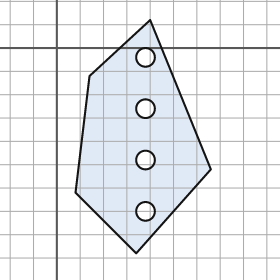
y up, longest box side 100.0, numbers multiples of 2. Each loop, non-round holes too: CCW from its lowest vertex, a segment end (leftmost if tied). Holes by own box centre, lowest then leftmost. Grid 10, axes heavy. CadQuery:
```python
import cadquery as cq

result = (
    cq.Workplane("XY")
    .moveTo(34.0, -88.0)
    .lineTo(66.0, -52.0)
    .lineTo(40.0, 12.0)
    .lineTo(14.0, -12.0)
    .lineTo(8.0, -62.0)
    .close()
    .moveTo(38.0, -70.0)
    .circle(4.0)
    .moveTo(38.0, -48.0)
    .circle(4.0)
    .moveTo(38.0, -26.0)
    .circle(4.0)
    .moveTo(38.0, -4.0)
    .circle(4.0)
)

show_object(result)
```